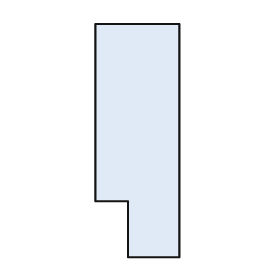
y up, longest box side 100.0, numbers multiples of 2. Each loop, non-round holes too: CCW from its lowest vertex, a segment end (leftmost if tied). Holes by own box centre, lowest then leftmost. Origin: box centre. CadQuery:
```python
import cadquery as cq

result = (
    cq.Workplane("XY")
    .moveTo(-4.0, -50.0)
    .lineTo(18.0, -50.0)
    .lineTo(18.0, 50.0)
    .lineTo(-18.0, 50.0)
    .lineTo(-18.0, -26.0)
    .lineTo(-4.0, -26.0)
    .close()
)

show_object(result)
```